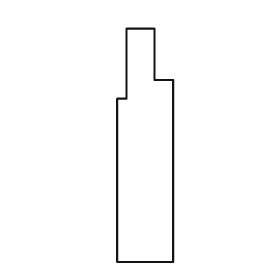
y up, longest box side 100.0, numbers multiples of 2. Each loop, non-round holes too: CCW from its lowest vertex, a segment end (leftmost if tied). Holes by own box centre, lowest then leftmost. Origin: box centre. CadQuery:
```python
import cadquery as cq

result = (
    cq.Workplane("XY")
    .moveTo(-12.0, -50.0)
    .lineTo(12.0, -50.0)
    .lineTo(12.0, 28.0)
    .lineTo(4.0, 28.0)
    .lineTo(4.0, 50.0)
    .lineTo(-8.0, 50.0)
    .lineTo(-8.0, 20.0)
    .lineTo(-12.0, 20.0)
    .close()
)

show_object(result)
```